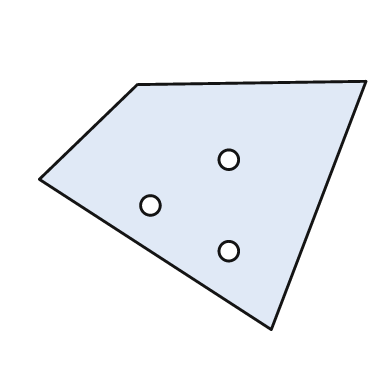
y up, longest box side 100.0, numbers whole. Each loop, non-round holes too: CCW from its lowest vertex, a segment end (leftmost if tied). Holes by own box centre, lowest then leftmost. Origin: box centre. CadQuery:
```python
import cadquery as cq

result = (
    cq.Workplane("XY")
    .moveTo(21.0, -38.0)
    .lineTo(50.0, 38.0)
    .lineTo(-20.0, 37.0)
    .lineTo(-50.0, 8.0)
    .close()
    .moveTo(8.0, -14.0)
    .circle(3.0)
    .moveTo(-16.0, 0.0)
    .circle(3.0)
    .moveTo(8.0, 14.0)
    .circle(3.0)
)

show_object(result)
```